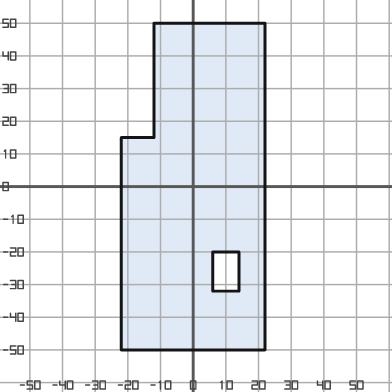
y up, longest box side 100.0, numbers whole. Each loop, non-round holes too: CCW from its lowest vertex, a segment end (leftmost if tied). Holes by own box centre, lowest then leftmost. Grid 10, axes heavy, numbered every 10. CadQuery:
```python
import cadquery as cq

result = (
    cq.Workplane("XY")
    .moveTo(-22.0, -50.0)
    .lineTo(22.0, -50.0)
    .lineTo(22.0, 50.0)
    .lineTo(-12.0, 50.0)
    .lineTo(-12.0, 15.0)
    .lineTo(-22.0, 15.0)
    .close()
    .moveTo(6.0, -32.0)
    .lineTo(14.0, -32.0)
    .lineTo(14.0, -20.0)
    .lineTo(6.0, -20.0)
    .close()
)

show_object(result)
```